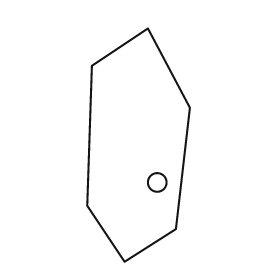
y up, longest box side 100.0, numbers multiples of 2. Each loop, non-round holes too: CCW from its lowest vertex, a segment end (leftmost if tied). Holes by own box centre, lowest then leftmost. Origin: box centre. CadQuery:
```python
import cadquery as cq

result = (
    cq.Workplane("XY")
    .moveTo(-6.0, -50.0)
    .lineTo(16.0, -36.0)
    .lineTo(22.0, 16.0)
    .lineTo(4.0, 50.0)
    .lineTo(-20.0, 34.0)
    .lineTo(-22.0, -26.0)
    .close()
    .moveTo(8.0, -16.0)
    .circle(4.0)
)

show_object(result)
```